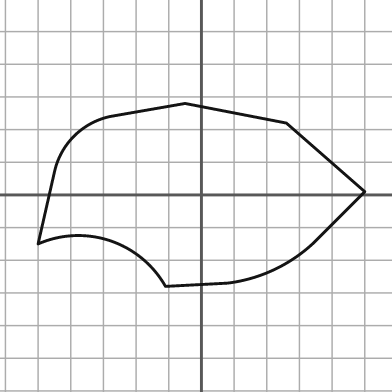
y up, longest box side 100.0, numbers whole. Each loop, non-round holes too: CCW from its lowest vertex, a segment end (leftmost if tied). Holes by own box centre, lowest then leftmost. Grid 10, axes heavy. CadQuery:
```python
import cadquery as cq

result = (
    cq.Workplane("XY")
    .moveTo(-11.0, -28.0)
    .lineTo(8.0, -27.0)
    .threePointArc((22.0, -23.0), (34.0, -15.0))
    .lineTo(50.0, 1.0)
    .lineTo(26.0, 22.0)
    .lineTo(-5.0, 28.0)
    .lineTo(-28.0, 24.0)
    .threePointArc((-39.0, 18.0), (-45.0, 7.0))
    .lineTo(-50.0, -15.0)
    .threePointArc((-28.0, -14.0), (-11.0, -28.0))
    .close()
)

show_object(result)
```